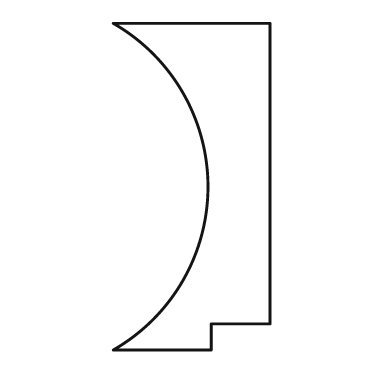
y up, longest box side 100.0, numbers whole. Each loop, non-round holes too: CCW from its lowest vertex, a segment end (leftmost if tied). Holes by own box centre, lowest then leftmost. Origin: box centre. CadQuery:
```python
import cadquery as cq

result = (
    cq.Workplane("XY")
    .moveTo(-24.0, -50.0)
    .lineTo(6.0, -50.0)
    .lineTo(6.0, -42.0)
    .lineTo(24.0, -42.0)
    .lineTo(24.0, 50.0)
    .lineTo(-24.0, 50.0)
    .threePointArc((5.0, 0.0), (-24.0, -50.0))
    .close()
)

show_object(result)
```